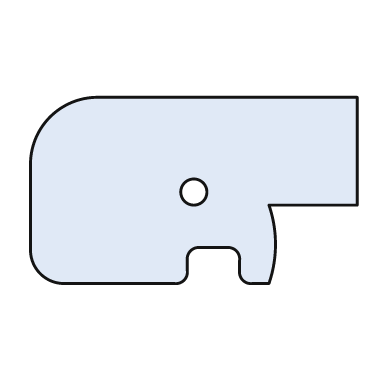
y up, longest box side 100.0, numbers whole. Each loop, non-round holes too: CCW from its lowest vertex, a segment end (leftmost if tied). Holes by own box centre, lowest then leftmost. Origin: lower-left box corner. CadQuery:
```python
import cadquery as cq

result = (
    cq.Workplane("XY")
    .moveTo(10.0, 0.0)
    .lineTo(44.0, 0.0)
    .threePointArc((47.0, 1.0), (48.0, 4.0))
    .lineTo(48.0, 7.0)
    .threePointArc((49.0, 10.0), (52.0, 11.0))
    .lineTo(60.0, 11.0)
    .threePointArc((63.0, 10.0), (64.0, 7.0))
    .lineTo(64.0, 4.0)
    .threePointArc((65.0, 1.0), (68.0, 0.0))
    .lineTo(73.0, 0.0)
    .threePointArc((75.0, 12.0), (73.0, 24.0))
    .lineTo(100.0, 24.0)
    .lineTo(100.0, 57.0)
    .lineTo(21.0, 57.0)
    .threePointArc((6.0, 51.0), (0.0, 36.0))
    .lineTo(0.0, 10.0)
    .threePointArc((3.0, 3.0), (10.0, 0.0))
    .close()
    .moveTo(50.0, 28.0)
    .circle(4.0)
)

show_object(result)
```